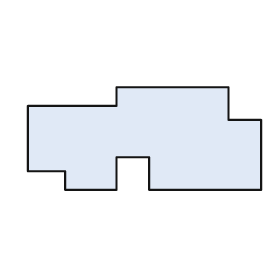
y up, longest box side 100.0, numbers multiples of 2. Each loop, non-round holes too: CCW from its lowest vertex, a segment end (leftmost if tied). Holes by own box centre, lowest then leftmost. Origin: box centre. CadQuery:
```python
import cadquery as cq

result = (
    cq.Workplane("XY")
    .moveTo(-34.0, -22.0)
    .lineTo(-12.0, -22.0)
    .lineTo(-12.0, -8.0)
    .lineTo(2.0, -8.0)
    .lineTo(2.0, -22.0)
    .lineTo(50.0, -22.0)
    .lineTo(50.0, 8.0)
    .lineTo(36.0, 8.0)
    .lineTo(36.0, 22.0)
    .lineTo(-12.0, 22.0)
    .lineTo(-12.0, 14.0)
    .lineTo(-50.0, 14.0)
    .lineTo(-50.0, -14.0)
    .lineTo(-34.0, -14.0)
    .close()
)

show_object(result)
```